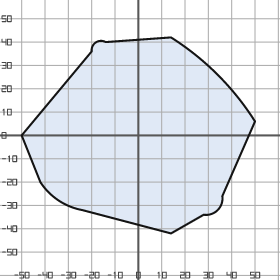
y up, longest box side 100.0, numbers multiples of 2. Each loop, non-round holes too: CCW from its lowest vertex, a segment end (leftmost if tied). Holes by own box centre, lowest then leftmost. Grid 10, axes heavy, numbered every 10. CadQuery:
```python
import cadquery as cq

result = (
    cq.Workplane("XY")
    .moveTo(14.0, -42.0)
    .lineTo(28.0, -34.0)
    .threePointArc((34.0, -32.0), (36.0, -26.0))
    .lineTo(50.0, 6.0)
    .threePointArc((34.0, 26.0), (14.0, 42.0))
    .lineTo(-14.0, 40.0)
    .threePointArc((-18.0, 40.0), (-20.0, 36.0))
    .lineTo(-50.0, 0.0)
    .lineTo(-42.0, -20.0)
    .threePointArc((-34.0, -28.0), (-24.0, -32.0))
    .close()
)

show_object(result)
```